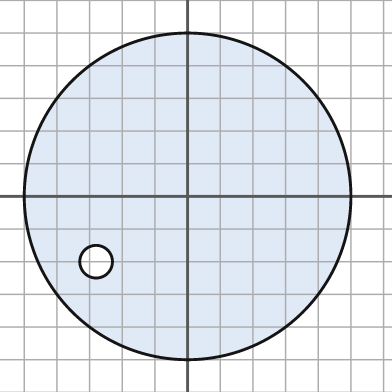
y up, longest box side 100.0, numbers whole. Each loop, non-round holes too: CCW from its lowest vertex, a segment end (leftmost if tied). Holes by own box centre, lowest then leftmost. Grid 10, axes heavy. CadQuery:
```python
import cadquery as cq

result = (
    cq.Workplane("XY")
    .moveTo(0.0, 0.0)
    .circle(50.0)
    .moveTo(-28.0, -20.0)
    .circle(5.0)
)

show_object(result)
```